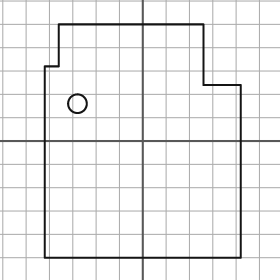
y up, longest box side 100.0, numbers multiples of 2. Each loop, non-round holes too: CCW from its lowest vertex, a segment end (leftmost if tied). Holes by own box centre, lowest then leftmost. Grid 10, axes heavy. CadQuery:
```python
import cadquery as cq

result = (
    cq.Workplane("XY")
    .moveTo(-42.0, -50.0)
    .lineTo(42.0, -50.0)
    .lineTo(42.0, 24.0)
    .lineTo(26.0, 24.0)
    .lineTo(26.0, 50.0)
    .lineTo(-36.0, 50.0)
    .lineTo(-36.0, 32.0)
    .lineTo(-42.0, 32.0)
    .close()
    .moveTo(-28.0, 16.0)
    .circle(4.0)
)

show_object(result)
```